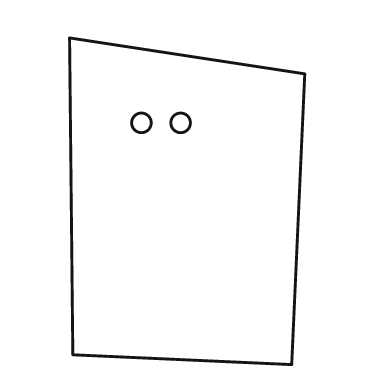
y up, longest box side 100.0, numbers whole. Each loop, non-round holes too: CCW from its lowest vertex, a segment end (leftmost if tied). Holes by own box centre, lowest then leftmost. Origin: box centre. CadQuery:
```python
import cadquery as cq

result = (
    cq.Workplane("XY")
    .moveTo(32.0, -50.0)
    .lineTo(36.0, 39.0)
    .lineTo(-36.0, 50.0)
    .lineTo(-35.0, -47.0)
    .close()
    .moveTo(-14.0, 24.0)
    .circle(3.0)
    .moveTo(-2.0, 24.0)
    .circle(3.0)
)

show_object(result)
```